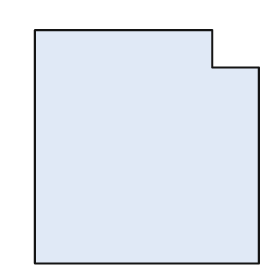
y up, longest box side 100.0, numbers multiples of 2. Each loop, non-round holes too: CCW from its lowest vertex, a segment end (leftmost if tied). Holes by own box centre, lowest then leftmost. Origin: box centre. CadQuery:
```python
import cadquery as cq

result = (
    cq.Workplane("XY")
    .moveTo(-48.0, -50.0)
    .lineTo(48.0, -50.0)
    .lineTo(48.0, 34.0)
    .lineTo(28.0, 34.0)
    .lineTo(28.0, 50.0)
    .lineTo(-48.0, 50.0)
    .close()
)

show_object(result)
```